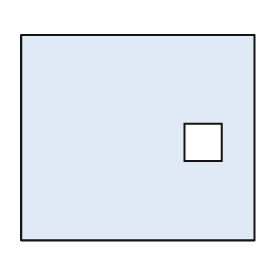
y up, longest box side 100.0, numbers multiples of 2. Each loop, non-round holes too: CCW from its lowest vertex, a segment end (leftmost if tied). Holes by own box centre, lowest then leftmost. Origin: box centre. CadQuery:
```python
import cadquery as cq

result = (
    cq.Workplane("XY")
    .moveTo(-50.0, -44.0)
    .lineTo(50.0, -44.0)
    .lineTo(50.0, 44.0)
    .lineTo(-50.0, 44.0)
    .close()
    .moveTo(20.0, -10.0)
    .lineTo(36.0, -10.0)
    .lineTo(36.0, 6.0)
    .lineTo(20.0, 6.0)
    .close()
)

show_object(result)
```